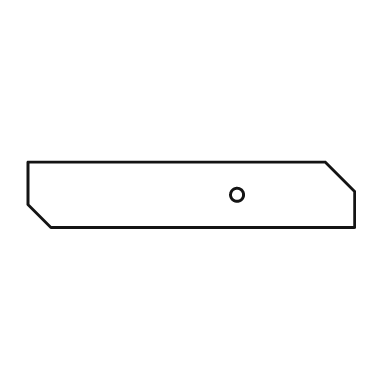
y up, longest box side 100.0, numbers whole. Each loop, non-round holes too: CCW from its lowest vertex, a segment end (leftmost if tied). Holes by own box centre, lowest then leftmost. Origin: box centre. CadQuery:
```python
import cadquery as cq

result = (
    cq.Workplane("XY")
    .moveTo(-43.0, -10.0)
    .lineTo(50.0, -10.0)
    .lineTo(50.0, 1.0)
    .lineTo(41.0, 10.0)
    .lineTo(-50.0, 10.0)
    .lineTo(-50.0, -3.0)
    .close()
    .moveTo(14.0, 0.0)
    .circle(2.0)
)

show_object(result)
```